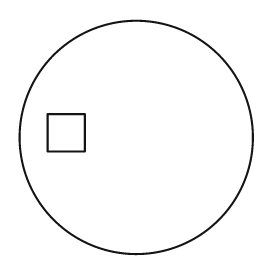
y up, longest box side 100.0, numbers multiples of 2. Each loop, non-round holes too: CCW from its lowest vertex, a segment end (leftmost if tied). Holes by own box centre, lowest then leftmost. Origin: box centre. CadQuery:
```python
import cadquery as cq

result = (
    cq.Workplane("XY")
    .moveTo(0.0, 0.0)
    .circle(50.0)
    .moveTo(-38.0, -6.0)
    .lineTo(-22.0, -6.0)
    .lineTo(-22.0, 10.0)
    .lineTo(-38.0, 10.0)
    .close()
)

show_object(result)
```